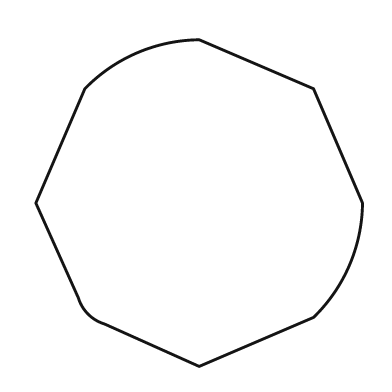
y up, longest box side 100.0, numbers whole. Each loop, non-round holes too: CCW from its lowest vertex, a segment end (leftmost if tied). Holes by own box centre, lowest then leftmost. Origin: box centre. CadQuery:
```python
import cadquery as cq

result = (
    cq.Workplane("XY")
    .moveTo(0.0, -50.0)
    .lineTo(35.0, -35.0)
    .threePointArc((46.0, -19.0), (50.0, 0.0))
    .lineTo(35.0, 35.0)
    .lineTo(0.0, 50.0)
    .threePointArc((-19.0, 46.0), (-35.0, 35.0))
    .lineTo(-50.0, 0.0)
    .lineTo(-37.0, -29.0)
    .threePointArc((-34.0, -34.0), (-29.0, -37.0))
    .close()
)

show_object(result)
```